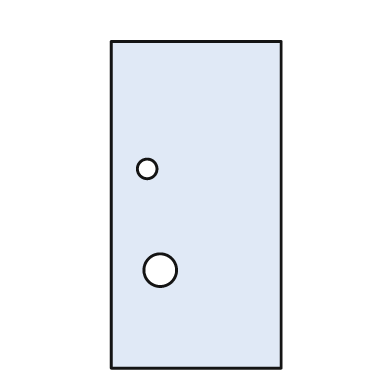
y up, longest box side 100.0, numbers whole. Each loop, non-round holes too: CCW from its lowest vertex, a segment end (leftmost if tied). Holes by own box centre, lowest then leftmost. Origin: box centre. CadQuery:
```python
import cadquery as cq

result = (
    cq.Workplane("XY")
    .moveTo(-26.0, -50.0)
    .lineTo(26.0, -50.0)
    .lineTo(26.0, 50.0)
    .lineTo(-26.0, 50.0)
    .close()
    .moveTo(-11.0, -20.0)
    .circle(5.0)
    .moveTo(-15.0, 11.0)
    .circle(3.0)
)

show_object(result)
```